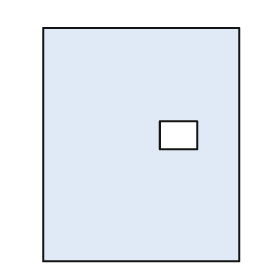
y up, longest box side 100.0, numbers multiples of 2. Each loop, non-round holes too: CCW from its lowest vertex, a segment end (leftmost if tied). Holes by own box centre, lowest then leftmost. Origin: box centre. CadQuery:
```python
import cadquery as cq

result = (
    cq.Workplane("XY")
    .moveTo(-42.0, -50.0)
    .lineTo(42.0, -50.0)
    .lineTo(42.0, 50.0)
    .lineTo(-42.0, 50.0)
    .close()
    .moveTo(8.0, -2.0)
    .lineTo(24.0, -2.0)
    .lineTo(24.0, 10.0)
    .lineTo(8.0, 10.0)
    .close()
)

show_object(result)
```